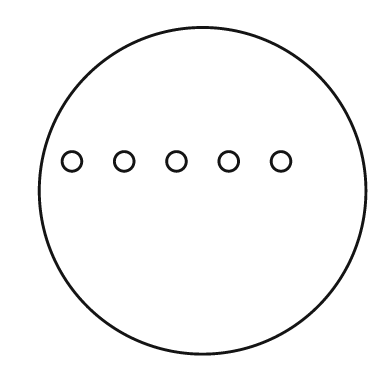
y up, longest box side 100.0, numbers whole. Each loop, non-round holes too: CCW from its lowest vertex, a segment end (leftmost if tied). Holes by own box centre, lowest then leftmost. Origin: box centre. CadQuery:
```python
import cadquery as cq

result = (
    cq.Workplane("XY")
    .moveTo(0.0, 0.0)
    .circle(50.0)
    .moveTo(-40.0, 9.0)
    .circle(3.0)
    .moveTo(-24.0, 9.0)
    .circle(3.0)
    .moveTo(-8.0, 9.0)
    .circle(3.0)
    .moveTo(8.0, 9.0)
    .circle(3.0)
    .moveTo(24.0, 9.0)
    .circle(3.0)
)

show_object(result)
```